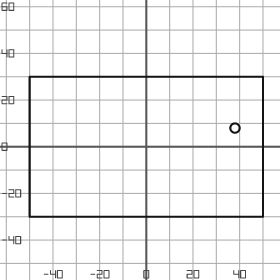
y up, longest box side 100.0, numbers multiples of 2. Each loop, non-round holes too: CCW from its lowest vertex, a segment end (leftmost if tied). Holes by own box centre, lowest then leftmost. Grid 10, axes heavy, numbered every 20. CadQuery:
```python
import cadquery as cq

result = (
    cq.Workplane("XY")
    .moveTo(-50.0, -30.0)
    .lineTo(50.0, -30.0)
    .lineTo(50.0, 30.0)
    .lineTo(-50.0, 30.0)
    .close()
    .moveTo(38.0, 8.0)
    .circle(2.0)
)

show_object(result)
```